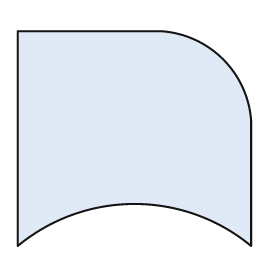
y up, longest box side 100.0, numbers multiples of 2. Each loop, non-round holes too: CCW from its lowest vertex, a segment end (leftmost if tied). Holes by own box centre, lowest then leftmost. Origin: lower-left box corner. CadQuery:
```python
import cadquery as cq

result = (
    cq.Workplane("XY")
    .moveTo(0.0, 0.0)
    .threePointArc((50.0, 18.0), (100.0, 0.0))
    .lineTo(100.0, 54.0)
    .threePointArc((88.0, 80.0), (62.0, 92.0))
    .lineTo(0.0, 92.0)
    .close()
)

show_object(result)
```